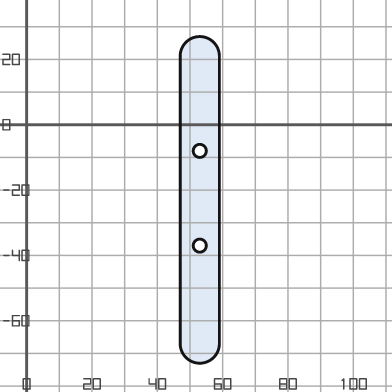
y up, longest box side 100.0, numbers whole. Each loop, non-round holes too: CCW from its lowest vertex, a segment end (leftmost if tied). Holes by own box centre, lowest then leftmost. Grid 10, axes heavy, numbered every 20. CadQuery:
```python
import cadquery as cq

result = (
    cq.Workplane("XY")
    .moveTo(47.0, -67.0)
    .threePointArc((53.0, -73.0), (59.0, -67.0))
    .lineTo(59.0, 21.0)
    .threePointArc((53.0, 27.0), (47.0, 21.0))
    .close()
    .moveTo(53.0, -37.0)
    .circle(2.0)
    .moveTo(53.0, -8.0)
    .circle(2.0)
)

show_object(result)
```